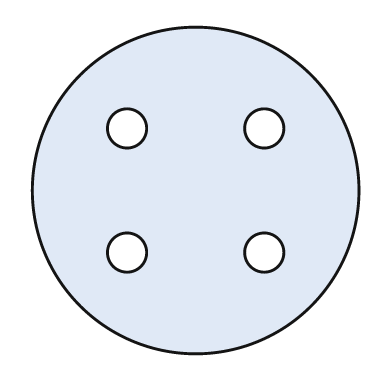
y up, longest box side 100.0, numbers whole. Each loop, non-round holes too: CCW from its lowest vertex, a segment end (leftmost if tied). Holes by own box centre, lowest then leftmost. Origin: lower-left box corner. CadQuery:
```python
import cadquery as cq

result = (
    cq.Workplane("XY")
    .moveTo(50.0, 50.0)
    .circle(50.0)
    .moveTo(29.0, 31.0)
    .circle(6.0)
    .moveTo(71.0, 31.0)
    .circle(6.0)
    .moveTo(29.0, 69.0)
    .circle(6.0)
    .moveTo(71.0, 69.0)
    .circle(6.0)
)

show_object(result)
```